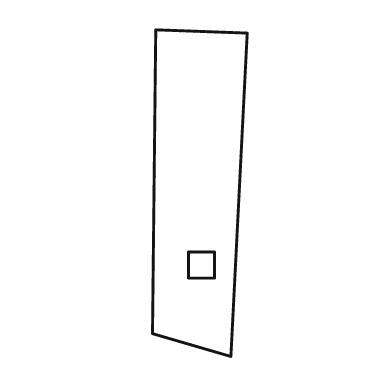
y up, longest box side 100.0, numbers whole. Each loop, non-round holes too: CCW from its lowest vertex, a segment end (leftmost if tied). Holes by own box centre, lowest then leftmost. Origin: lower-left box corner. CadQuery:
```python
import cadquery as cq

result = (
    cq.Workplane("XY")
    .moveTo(24.0, 0.0)
    .lineTo(29.0, 99.0)
    .lineTo(1.0, 100.0)
    .lineTo(0.0, 7.0)
    .close()
    .moveTo(11.0, 24.0)
    .lineTo(19.0, 24.0)
    .lineTo(19.0, 32.0)
    .lineTo(11.0, 32.0)
    .close()
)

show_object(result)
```